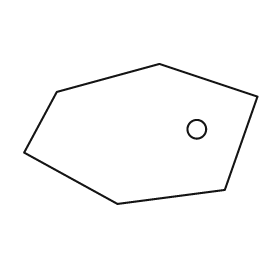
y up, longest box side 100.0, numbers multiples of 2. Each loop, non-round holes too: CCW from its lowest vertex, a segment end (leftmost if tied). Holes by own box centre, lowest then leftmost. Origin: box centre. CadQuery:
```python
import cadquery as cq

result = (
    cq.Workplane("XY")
    .moveTo(-10.0, -30.0)
    .lineTo(36.0, -24.0)
    .lineTo(50.0, 16.0)
    .lineTo(8.0, 30.0)
    .lineTo(-36.0, 18.0)
    .lineTo(-50.0, -8.0)
    .close()
    .moveTo(24.0, 2.0)
    .circle(4.0)
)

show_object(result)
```